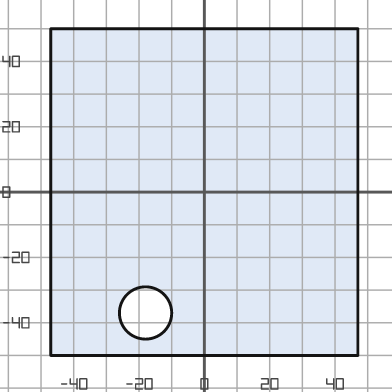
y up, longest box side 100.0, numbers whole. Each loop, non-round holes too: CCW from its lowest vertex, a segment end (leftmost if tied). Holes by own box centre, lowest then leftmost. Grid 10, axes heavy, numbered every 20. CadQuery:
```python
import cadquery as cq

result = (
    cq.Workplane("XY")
    .moveTo(-47.0, -50.0)
    .lineTo(47.0, -50.0)
    .lineTo(47.0, 50.0)
    .lineTo(-47.0, 50.0)
    .close()
    .moveTo(-18.0, -37.0)
    .circle(8.0)
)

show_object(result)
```